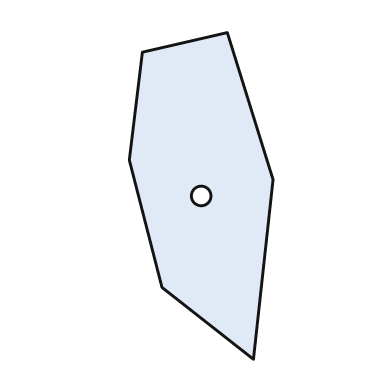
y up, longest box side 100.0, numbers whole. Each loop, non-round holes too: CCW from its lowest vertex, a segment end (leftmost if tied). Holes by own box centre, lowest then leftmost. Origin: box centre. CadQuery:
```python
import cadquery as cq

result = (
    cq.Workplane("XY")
    .moveTo(16.0, -50.0)
    .lineTo(22.0, 5.0)
    .lineTo(8.0, 50.0)
    .lineTo(-18.0, 44.0)
    .lineTo(-22.0, 11.0)
    .lineTo(-12.0, -28.0)
    .close()
    .moveTo(0.0, 0.0)
    .circle(3.0)
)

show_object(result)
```